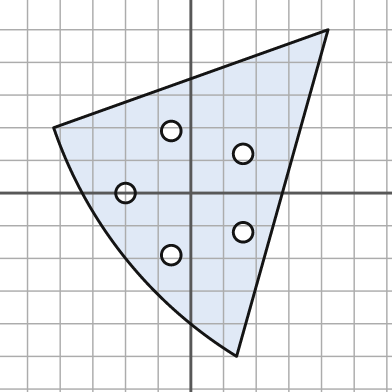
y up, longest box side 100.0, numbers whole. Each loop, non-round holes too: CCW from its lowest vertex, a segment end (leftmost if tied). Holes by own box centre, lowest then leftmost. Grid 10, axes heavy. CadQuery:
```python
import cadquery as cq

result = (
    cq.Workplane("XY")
    .moveTo(14.0, -50.0)
    .lineTo(42.0, 50.0)
    .lineTo(-42.0, 20.0)
    .threePointArc((-20.0, -20.0), (14.0, -50.0))
    .close()
    .moveTo(-6.0, -19.0)
    .circle(3.0)
    .moveTo(16.0, -12.0)
    .circle(3.0)
    .moveTo(-20.0, 0.0)
    .circle(3.0)
    .moveTo(16.0, 12.0)
    .circle(3.0)
    .moveTo(-6.0, 19.0)
    .circle(3.0)
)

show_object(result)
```